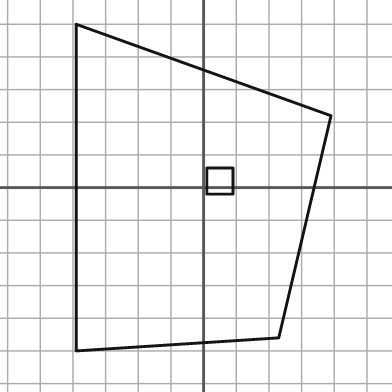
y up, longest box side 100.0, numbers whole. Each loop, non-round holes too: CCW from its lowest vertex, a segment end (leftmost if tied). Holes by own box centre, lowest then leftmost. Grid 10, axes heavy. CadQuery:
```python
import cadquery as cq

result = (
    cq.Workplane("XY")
    .moveTo(-39.0, -50.0)
    .lineTo(23.0, -46.0)
    .lineTo(39.0, 22.0)
    .lineTo(-39.0, 50.0)
    .close()
    .moveTo(1.0, -2.0)
    .lineTo(9.0, -2.0)
    .lineTo(9.0, 6.0)
    .lineTo(1.0, 6.0)
    .close()
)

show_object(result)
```